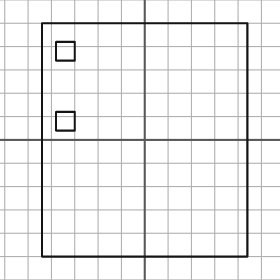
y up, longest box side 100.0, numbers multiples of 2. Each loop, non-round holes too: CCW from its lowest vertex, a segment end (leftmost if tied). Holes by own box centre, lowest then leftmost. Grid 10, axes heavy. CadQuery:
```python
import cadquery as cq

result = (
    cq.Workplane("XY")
    .moveTo(-44.0, -50.0)
    .lineTo(44.0, -50.0)
    .lineTo(44.0, 50.0)
    .lineTo(-44.0, 50.0)
    .close()
    .moveTo(-38.0, 4.0)
    .lineTo(-30.0, 4.0)
    .lineTo(-30.0, 12.0)
    .lineTo(-38.0, 12.0)
    .close()
    .moveTo(-38.0, 34.0)
    .lineTo(-30.0, 34.0)
    .lineTo(-30.0, 42.0)
    .lineTo(-38.0, 42.0)
    .close()
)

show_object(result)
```